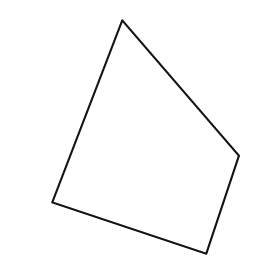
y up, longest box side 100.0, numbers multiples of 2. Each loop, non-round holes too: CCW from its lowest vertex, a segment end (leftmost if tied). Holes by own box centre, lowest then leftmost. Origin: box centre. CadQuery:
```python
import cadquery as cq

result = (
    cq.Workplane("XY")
    .moveTo(26.0, -50.0)
    .lineTo(40.0, -8.0)
    .lineTo(-10.0, 50.0)
    .lineTo(-40.0, -28.0)
    .close()
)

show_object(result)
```